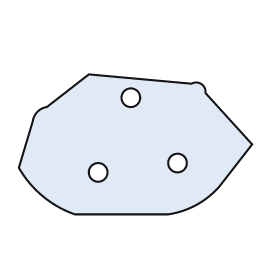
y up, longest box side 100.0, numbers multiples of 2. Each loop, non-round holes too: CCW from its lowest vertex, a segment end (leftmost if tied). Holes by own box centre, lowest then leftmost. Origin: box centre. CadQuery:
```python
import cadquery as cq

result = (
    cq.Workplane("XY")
    .moveTo(-26.0, -30.0)
    .lineTo(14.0, -30.0)
    .threePointArc((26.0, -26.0), (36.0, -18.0))
    .lineTo(50.0, 0.0)
    .lineTo(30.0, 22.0)
    .threePointArc((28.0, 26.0), (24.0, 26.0))
    .lineTo(-20.0, 30.0)
    .lineTo(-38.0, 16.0)
    .threePointArc((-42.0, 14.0), (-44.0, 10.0))
    .lineTo(-50.0, -10.0)
    .threePointArc((-40.0, -22.0), (-26.0, -30.0))
    .close()
    .moveTo(-16.0, -12.0)
    .circle(4.0)
    .moveTo(18.0, -8.0)
    .circle(4.0)
    .moveTo(-2.0, 20.0)
    .circle(4.0)
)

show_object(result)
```